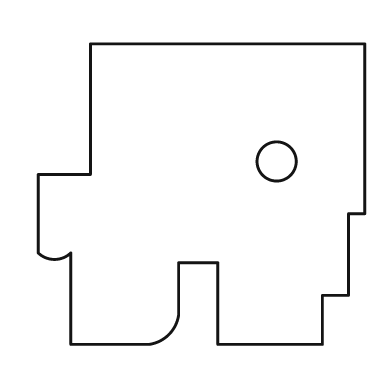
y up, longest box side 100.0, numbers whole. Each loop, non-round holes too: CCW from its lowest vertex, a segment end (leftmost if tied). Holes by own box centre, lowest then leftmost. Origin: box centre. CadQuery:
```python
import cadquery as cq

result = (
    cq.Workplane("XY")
    .moveTo(-40.0, -46.0)
    .lineTo(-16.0, -46.0)
    .threePointArc((-10.0, -43.0), (-7.0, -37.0))
    .lineTo(-7.0, -21.0)
    .lineTo(5.0, -21.0)
    .lineTo(5.0, -46.0)
    .lineTo(37.0, -46.0)
    .lineTo(37.0, -31.0)
    .lineTo(45.0, -31.0)
    .lineTo(45.0, -6.0)
    .lineTo(50.0, -6.0)
    .lineTo(50.0, 46.0)
    .lineTo(-34.0, 46.0)
    .lineTo(-34.0, 6.0)
    .lineTo(-50.0, 6.0)
    .lineTo(-50.0, -18.0)
    .threePointArc((-45.0, -20.0), (-40.0, -18.0))
    .close()
    .moveTo(23.0, 10.0)
    .circle(6.0)
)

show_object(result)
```